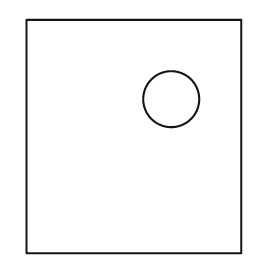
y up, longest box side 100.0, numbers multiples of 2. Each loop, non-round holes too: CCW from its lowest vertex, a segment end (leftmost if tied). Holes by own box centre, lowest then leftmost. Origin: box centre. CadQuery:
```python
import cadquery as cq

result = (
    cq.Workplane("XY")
    .moveTo(-46.0, -50.0)
    .lineTo(46.0, -50.0)
    .lineTo(46.0, 50.0)
    .lineTo(-46.0, 50.0)
    .close()
    .moveTo(16.0, 16.0)
    .circle(12.0)
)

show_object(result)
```